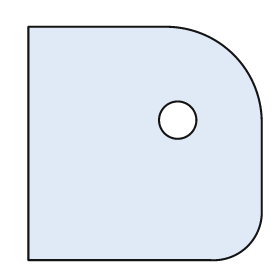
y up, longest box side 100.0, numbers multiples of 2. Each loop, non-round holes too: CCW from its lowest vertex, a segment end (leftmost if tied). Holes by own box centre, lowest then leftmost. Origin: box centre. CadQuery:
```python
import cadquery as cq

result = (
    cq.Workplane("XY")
    .moveTo(-50.0, -50.0)
    .lineTo(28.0, -50.0)
    .threePointArc((44.0, -44.0), (50.0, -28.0))
    .lineTo(50.0, 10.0)
    .threePointArc((38.0, 38.0), (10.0, 50.0))
    .lineTo(-50.0, 50.0)
    .close()
    .moveTo(14.0, 10.0)
    .circle(8.0)
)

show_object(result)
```